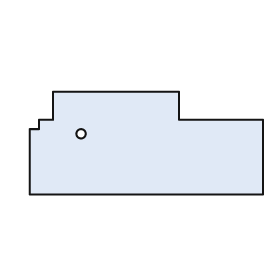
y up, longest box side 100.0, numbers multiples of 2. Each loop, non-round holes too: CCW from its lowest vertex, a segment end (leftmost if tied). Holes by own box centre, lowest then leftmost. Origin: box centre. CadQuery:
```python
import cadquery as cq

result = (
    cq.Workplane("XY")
    .moveTo(-50.0, -22.0)
    .lineTo(50.0, -22.0)
    .lineTo(50.0, 10.0)
    .lineTo(14.0, 10.0)
    .lineTo(14.0, 22.0)
    .lineTo(-40.0, 22.0)
    .lineTo(-40.0, 10.0)
    .lineTo(-46.0, 10.0)
    .lineTo(-46.0, 6.0)
    .lineTo(-50.0, 6.0)
    .close()
    .moveTo(-28.0, 4.0)
    .circle(2.0)
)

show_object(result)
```